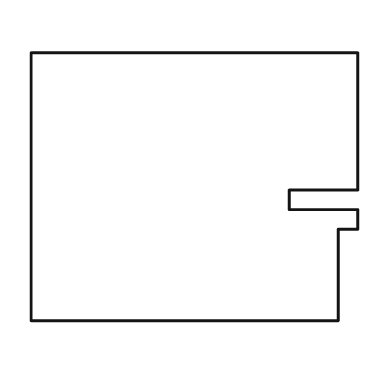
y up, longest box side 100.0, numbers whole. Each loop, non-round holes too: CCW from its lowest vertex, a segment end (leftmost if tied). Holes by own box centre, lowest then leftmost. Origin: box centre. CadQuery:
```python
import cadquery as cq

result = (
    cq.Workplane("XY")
    .moveTo(-50.0, -41.0)
    .lineTo(44.0, -41.0)
    .lineTo(44.0, -13.0)
    .lineTo(50.0, -13.0)
    .lineTo(50.0, -7.0)
    .lineTo(29.0, -7.0)
    .lineTo(29.0, -1.0)
    .lineTo(50.0, -1.0)
    .lineTo(50.0, 41.0)
    .lineTo(-50.0, 41.0)
    .close()
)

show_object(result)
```